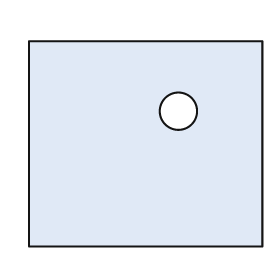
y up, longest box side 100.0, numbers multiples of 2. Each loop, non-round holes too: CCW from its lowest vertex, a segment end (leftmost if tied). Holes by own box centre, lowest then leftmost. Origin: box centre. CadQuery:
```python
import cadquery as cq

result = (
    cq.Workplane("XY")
    .moveTo(-50.0, -44.0)
    .lineTo(50.0, -44.0)
    .lineTo(50.0, 44.0)
    .lineTo(-50.0, 44.0)
    .close()
    .moveTo(14.0, 14.0)
    .circle(8.0)
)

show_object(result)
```